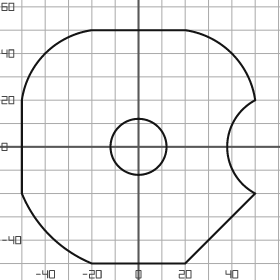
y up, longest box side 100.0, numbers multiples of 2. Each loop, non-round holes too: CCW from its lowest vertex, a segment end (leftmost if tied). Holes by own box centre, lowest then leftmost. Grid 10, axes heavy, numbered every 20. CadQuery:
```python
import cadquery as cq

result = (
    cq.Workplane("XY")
    .moveTo(-20.0, -50.0)
    .lineTo(20.0, -50.0)
    .lineTo(50.0, -20.0)
    .threePointArc((38.0, 0.0), (50.0, 20.0))
    .threePointArc((40.0, 40.0), (20.0, 50.0))
    .lineTo(-20.0, 50.0)
    .threePointArc((-40.0, 40.0), (-50.0, 20.0))
    .lineTo(-50.0, -20.0)
    .threePointArc((-38.0, -38.0), (-20.0, -50.0))
    .close()
    .moveTo(0.0, 0.0)
    .circle(12.0)
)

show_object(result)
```